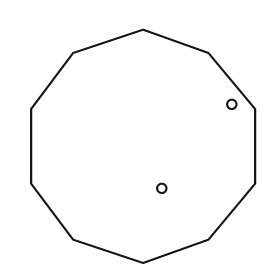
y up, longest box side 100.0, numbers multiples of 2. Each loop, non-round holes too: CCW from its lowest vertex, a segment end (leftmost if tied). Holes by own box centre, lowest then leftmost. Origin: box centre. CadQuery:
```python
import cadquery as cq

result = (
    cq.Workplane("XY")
    .moveTo(0.0, -50.0)
    .lineTo(28.0, -40.0)
    .lineTo(48.0, -16.0)
    .lineTo(48.0, 16.0)
    .lineTo(28.0, 40.0)
    .lineTo(0.0, 50.0)
    .lineTo(-30.0, 40.0)
    .lineTo(-48.0, 16.0)
    .lineTo(-48.0, -16.0)
    .lineTo(-30.0, -40.0)
    .close()
    .moveTo(8.0, -18.0)
    .circle(2.0)
    .moveTo(38.0, 18.0)
    .circle(2.0)
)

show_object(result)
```